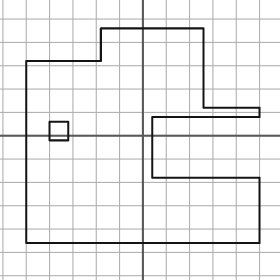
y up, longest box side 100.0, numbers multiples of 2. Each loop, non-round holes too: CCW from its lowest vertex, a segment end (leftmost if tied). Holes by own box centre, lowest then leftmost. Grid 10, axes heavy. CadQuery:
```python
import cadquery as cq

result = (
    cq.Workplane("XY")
    .moveTo(-50.0, -46.0)
    .lineTo(50.0, -46.0)
    .lineTo(50.0, -18.0)
    .lineTo(4.0, -18.0)
    .lineTo(4.0, 8.0)
    .lineTo(50.0, 8.0)
    .lineTo(50.0, 12.0)
    .lineTo(26.0, 12.0)
    .lineTo(26.0, 46.0)
    .lineTo(-18.0, 46.0)
    .lineTo(-18.0, 32.0)
    .lineTo(-50.0, 32.0)
    .close()
    .moveTo(-40.0, -2.0)
    .lineTo(-32.0, -2.0)
    .lineTo(-32.0, 6.0)
    .lineTo(-40.0, 6.0)
    .close()
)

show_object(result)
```